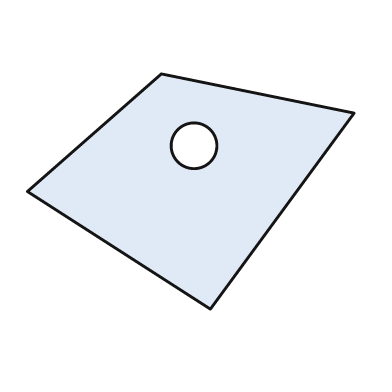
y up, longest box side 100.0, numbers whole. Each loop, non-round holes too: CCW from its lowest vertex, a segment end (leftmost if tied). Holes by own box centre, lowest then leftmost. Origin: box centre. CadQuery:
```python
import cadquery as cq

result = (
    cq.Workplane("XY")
    .moveTo(6.0, -36.0)
    .lineTo(50.0, 24.0)
    .lineTo(-9.0, 36.0)
    .lineTo(-50.0, 0.0)
    .close()
    .moveTo(1.0, 14.0)
    .circle(7.0)
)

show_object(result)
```